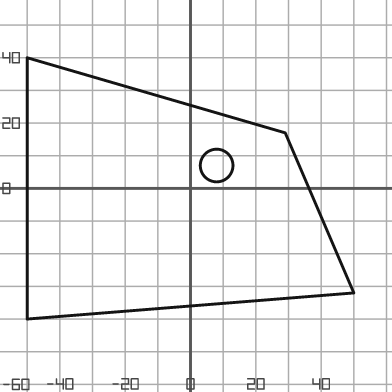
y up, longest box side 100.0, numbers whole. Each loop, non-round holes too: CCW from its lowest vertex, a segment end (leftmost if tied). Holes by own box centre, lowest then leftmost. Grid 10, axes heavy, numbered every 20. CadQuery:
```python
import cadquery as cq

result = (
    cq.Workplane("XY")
    .moveTo(-50.0, -40.0)
    .lineTo(50.0, -32.0)
    .lineTo(29.0, 17.0)
    .lineTo(-50.0, 40.0)
    .close()
    .moveTo(8.0, 7.0)
    .circle(5.0)
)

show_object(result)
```